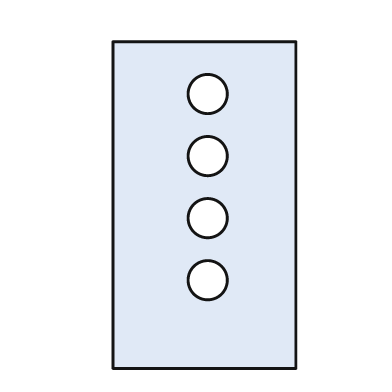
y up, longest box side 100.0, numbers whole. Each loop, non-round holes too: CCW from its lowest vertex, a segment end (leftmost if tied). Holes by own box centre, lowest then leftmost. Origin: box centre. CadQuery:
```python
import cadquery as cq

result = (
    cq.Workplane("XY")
    .moveTo(-28.0, -50.0)
    .lineTo(28.0, -50.0)
    .lineTo(28.0, 50.0)
    .lineTo(-28.0, 50.0)
    .close()
    .moveTo(1.0, -23.0)
    .circle(6.0)
    .moveTo(1.0, -4.0)
    .circle(6.0)
    .moveTo(1.0, 15.0)
    .circle(6.0)
    .moveTo(1.0, 34.0)
    .circle(6.0)
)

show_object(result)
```